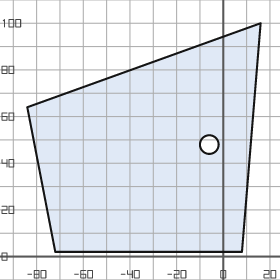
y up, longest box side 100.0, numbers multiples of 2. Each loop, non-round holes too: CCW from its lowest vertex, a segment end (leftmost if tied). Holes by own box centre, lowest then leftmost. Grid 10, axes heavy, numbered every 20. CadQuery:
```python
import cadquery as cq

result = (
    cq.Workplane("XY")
    .moveTo(-72.0, 2.0)
    .lineTo(8.0, 2.0)
    .lineTo(16.0, 100.0)
    .lineTo(-84.0, 64.0)
    .close()
    .moveTo(-6.0, 48.0)
    .circle(4.0)
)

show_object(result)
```